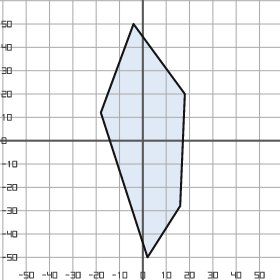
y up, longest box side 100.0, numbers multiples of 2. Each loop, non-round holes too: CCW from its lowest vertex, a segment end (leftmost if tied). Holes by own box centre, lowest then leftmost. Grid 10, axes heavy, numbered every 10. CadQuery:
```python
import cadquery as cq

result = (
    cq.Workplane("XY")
    .moveTo(2.0, -50.0)
    .lineTo(16.0, -28.0)
    .lineTo(18.0, 20.0)
    .lineTo(-4.0, 50.0)
    .lineTo(-18.0, 12.0)
    .close()
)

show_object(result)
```